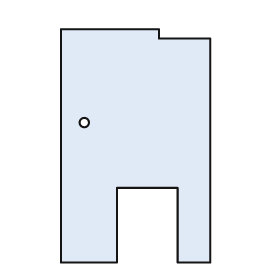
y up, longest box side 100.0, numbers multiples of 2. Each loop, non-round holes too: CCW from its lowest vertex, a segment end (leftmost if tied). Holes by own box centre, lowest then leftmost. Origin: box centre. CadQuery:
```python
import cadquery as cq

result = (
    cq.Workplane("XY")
    .moveTo(-32.0, -50.0)
    .lineTo(-8.0, -50.0)
    .lineTo(-8.0, -18.0)
    .lineTo(18.0, -18.0)
    .lineTo(18.0, -50.0)
    .lineTo(32.0, -50.0)
    .lineTo(32.0, 46.0)
    .lineTo(10.0, 46.0)
    .lineTo(10.0, 50.0)
    .lineTo(-32.0, 50.0)
    .close()
    .moveTo(-22.0, 10.0)
    .circle(2.0)
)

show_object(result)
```